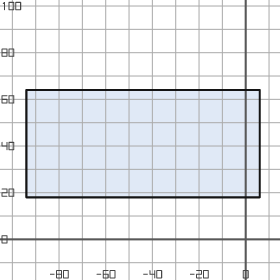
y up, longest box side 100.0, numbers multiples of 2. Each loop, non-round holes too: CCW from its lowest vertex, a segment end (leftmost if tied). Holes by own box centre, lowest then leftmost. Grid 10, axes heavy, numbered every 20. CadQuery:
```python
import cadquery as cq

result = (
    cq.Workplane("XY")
    .moveTo(-94.0, 18.0)
    .lineTo(6.0, 18.0)
    .lineTo(6.0, 64.0)
    .lineTo(-94.0, 64.0)
    .close()
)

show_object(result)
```